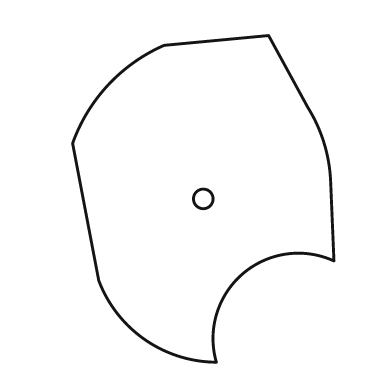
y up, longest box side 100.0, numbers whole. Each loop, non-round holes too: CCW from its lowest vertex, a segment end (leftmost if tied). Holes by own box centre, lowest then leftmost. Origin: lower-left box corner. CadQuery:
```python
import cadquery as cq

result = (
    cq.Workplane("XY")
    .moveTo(44.0, 0.0)
    .threePointArc((52.0, 27.0), (80.0, 31.0))
    .lineTo(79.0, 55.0)
    .threePointArc((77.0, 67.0), (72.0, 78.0))
    .lineTo(60.0, 100.0)
    .lineTo(28.0, 97.0)
    .threePointArc((11.0, 85.0), (0.0, 67.0))
    .lineTo(8.0, 25.0)
    .threePointArc((22.0, 7.0), (44.0, 0.0))
    .close()
    .moveTo(40.0, 50.0)
    .circle(3.0)
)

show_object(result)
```